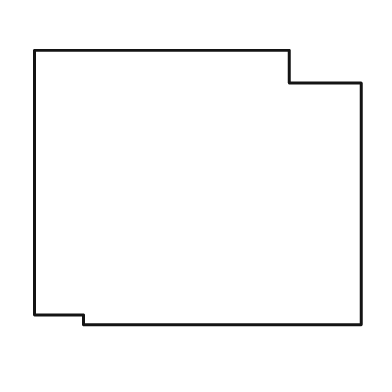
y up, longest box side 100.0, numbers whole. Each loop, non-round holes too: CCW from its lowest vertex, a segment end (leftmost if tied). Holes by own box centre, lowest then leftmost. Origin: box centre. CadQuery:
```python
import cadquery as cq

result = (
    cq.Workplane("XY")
    .moveTo(-35.0, -42.0)
    .lineTo(50.0, -42.0)
    .lineTo(50.0, 32.0)
    .lineTo(28.0, 32.0)
    .lineTo(28.0, 42.0)
    .lineTo(-50.0, 42.0)
    .lineTo(-50.0, -39.0)
    .lineTo(-35.0, -39.0)
    .close()
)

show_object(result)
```